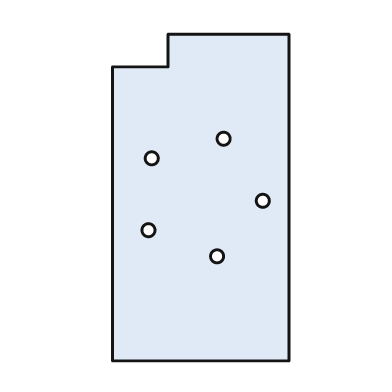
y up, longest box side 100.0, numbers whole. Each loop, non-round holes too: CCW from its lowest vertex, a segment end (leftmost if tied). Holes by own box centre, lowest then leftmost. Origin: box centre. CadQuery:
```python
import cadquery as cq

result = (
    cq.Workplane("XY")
    .moveTo(-27.0, -50.0)
    .lineTo(27.0, -50.0)
    .lineTo(27.0, 50.0)
    .lineTo(-10.0, 50.0)
    .lineTo(-10.0, 40.0)
    .lineTo(-27.0, 40.0)
    .close()
    .moveTo(5.0, -18.0)
    .circle(2.0)
    .moveTo(-16.0, -10.0)
    .circle(2.0)
    .moveTo(19.0, -1.0)
    .circle(2.0)
    .moveTo(-15.0, 12.0)
    .circle(2.0)
    .moveTo(7.0, 18.0)
    .circle(2.0)
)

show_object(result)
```